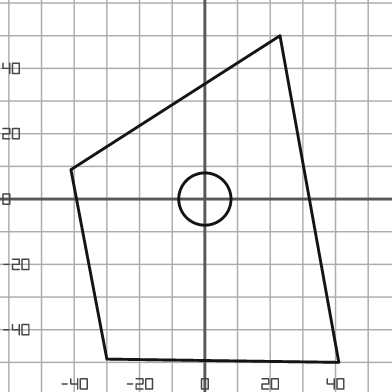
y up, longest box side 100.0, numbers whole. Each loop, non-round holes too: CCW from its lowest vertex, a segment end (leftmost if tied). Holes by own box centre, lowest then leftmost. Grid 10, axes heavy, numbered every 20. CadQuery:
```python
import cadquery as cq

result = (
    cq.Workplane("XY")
    .moveTo(41.0, -50.0)
    .lineTo(23.0, 50.0)
    .lineTo(-41.0, 9.0)
    .lineTo(-30.0, -49.0)
    .close()
    .moveTo(0.0, 0.0)
    .circle(8.0)
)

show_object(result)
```